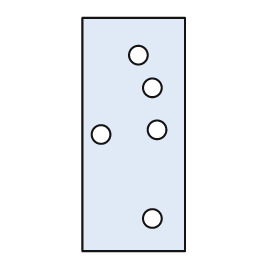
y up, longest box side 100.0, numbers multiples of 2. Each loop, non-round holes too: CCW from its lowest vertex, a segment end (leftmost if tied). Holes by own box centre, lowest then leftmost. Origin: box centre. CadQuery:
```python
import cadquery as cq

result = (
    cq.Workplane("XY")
    .moveTo(-22.0, -50.0)
    .lineTo(22.0, -50.0)
    .lineTo(22.0, 50.0)
    .lineTo(-22.0, 50.0)
    .close()
    .moveTo(8.0, -36.0)
    .circle(4.0)
    .moveTo(-14.0, 0.0)
    .circle(4.0)
    .moveTo(10.0, 2.0)
    .circle(4.0)
    .moveTo(8.0, 20.0)
    .circle(4.0)
    .moveTo(2.0, 34.0)
    .circle(4.0)
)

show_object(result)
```